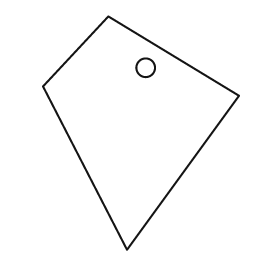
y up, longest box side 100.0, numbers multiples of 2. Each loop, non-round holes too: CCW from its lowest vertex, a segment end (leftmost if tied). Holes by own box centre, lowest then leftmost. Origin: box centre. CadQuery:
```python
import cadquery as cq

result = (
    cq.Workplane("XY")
    .moveTo(-6.0, -50.0)
    .lineTo(42.0, 16.0)
    .lineTo(-14.0, 50.0)
    .lineTo(-42.0, 20.0)
    .close()
    .moveTo(2.0, 28.0)
    .circle(4.0)
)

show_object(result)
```